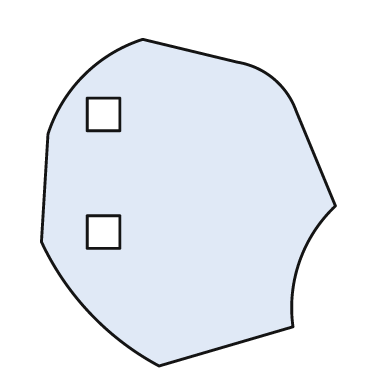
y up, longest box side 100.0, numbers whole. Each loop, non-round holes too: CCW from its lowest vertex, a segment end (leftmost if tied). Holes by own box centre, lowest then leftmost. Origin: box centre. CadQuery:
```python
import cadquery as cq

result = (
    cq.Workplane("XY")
    .moveTo(-9.0, -50.0)
    .lineTo(32.0, -38.0)
    .threePointArc((34.0, -18.0), (45.0, -1.0))
    .lineTo(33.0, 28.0)
    .threePointArc((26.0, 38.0), (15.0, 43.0))
    .lineTo(-14.0, 50.0)
    .threePointArc((-32.0, 39.0), (-43.0, 21.0))
    .lineTo(-45.0, -12.0)
    .threePointArc((-30.0, -34.0), (-9.0, -50.0))
    .close()
    .moveTo(-31.0, -14.0)
    .lineTo(-21.0, -14.0)
    .lineTo(-21.0, -4.0)
    .lineTo(-31.0, -4.0)
    .close()
    .moveTo(-31.0, 22.0)
    .lineTo(-21.0, 22.0)
    .lineTo(-21.0, 32.0)
    .lineTo(-31.0, 32.0)
    .close()
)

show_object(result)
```